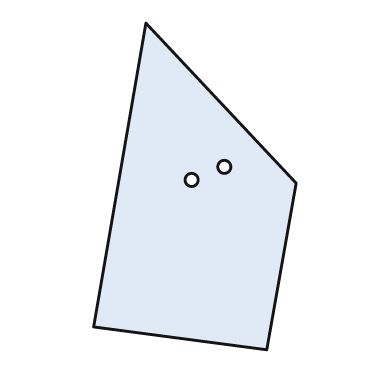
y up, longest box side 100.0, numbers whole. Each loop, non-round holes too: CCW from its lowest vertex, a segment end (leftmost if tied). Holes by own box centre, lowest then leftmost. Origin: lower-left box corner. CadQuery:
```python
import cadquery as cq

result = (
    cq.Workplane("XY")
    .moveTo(53.0, 0.0)
    .lineTo(62.0, 51.0)
    .lineTo(16.0, 100.0)
    .lineTo(0.0, 7.0)
    .close()
    .moveTo(30.0, 52.0)
    .circle(2.0)
    .moveTo(40.0, 56.0)
    .circle(2.0)
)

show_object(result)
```